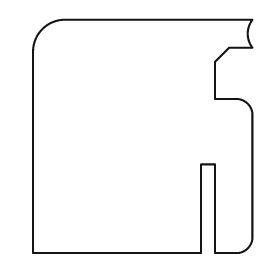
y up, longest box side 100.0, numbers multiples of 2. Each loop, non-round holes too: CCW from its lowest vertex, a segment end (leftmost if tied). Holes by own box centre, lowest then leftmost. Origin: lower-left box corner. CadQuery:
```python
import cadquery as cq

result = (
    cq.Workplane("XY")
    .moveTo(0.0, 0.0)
    .lineTo(72.0, 0.0)
    .lineTo(72.0, 38.0)
    .lineTo(78.0, 38.0)
    .lineTo(78.0, 0.0)
    .lineTo(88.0, 0.0)
    .threePointArc((92.0, 2.0), (94.0, 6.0))
    .lineTo(94.0, 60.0)
    .threePointArc((92.0, 64.0), (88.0, 66.0))
    .lineTo(78.0, 66.0)
    .lineTo(78.0, 82.0)
    .lineTo(84.0, 88.0)
    .lineTo(94.0, 88.0)
    .threePointArc((92.0, 94.0), (94.0, 100.0))
    .lineTo(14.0, 100.0)
    .threePointArc((4.0, 96.0), (0.0, 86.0))
    .close()
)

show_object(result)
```